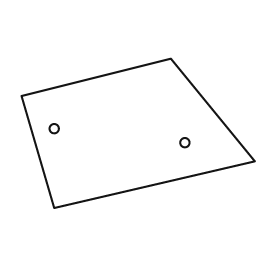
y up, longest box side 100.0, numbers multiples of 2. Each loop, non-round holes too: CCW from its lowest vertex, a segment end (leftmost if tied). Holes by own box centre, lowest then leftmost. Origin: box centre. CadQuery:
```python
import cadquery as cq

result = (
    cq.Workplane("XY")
    .moveTo(-36.0, -32.0)
    .lineTo(50.0, -12.0)
    .lineTo(14.0, 32.0)
    .lineTo(-50.0, 16.0)
    .close()
    .moveTo(20.0, -4.0)
    .circle(2.0)
    .moveTo(-36.0, 2.0)
    .circle(2.0)
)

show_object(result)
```